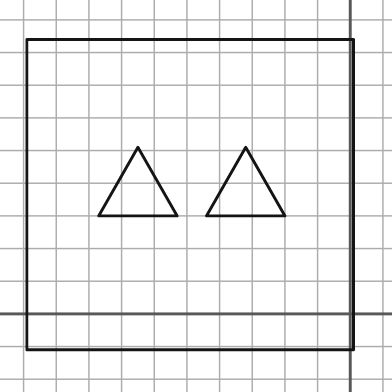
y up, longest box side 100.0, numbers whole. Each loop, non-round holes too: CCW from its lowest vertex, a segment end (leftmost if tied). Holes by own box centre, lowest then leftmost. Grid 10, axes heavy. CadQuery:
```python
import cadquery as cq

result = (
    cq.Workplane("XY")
    .moveTo(-99.0, -11.0)
    .lineTo(1.0, -11.0)
    .lineTo(1.0, 84.0)
    .lineTo(-99.0, 84.0)
    .close()
    .moveTo(-77.0, 30.0)
    .lineTo(-53.0, 30.0)
    .lineTo(-65.0, 51.0)
    .close()
    .moveTo(-44.0, 30.0)
    .lineTo(-20.0, 30.0)
    .lineTo(-32.0, 51.0)
    .close()
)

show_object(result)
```